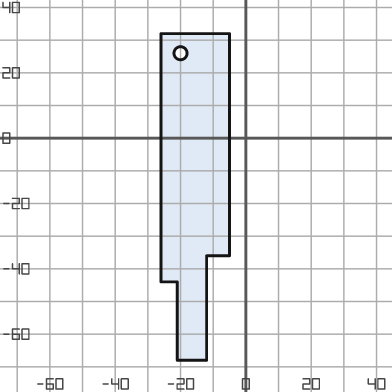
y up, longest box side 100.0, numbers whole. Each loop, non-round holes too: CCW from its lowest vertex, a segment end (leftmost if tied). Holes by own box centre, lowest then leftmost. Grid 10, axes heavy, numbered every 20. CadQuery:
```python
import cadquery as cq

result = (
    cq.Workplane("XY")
    .moveTo(-21.0, -68.0)
    .lineTo(-12.0, -68.0)
    .lineTo(-12.0, -36.0)
    .lineTo(-5.0, -36.0)
    .lineTo(-5.0, 32.0)
    .lineTo(-26.0, 32.0)
    .lineTo(-26.0, -44.0)
    .lineTo(-21.0, -44.0)
    .close()
    .moveTo(-20.0, 26.0)
    .circle(2.0)
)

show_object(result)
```